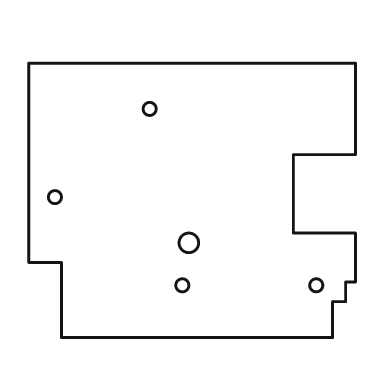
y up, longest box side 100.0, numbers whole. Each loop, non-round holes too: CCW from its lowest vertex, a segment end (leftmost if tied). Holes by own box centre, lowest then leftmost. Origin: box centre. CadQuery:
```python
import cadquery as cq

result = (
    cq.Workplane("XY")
    .moveTo(-40.0, -42.0)
    .lineTo(43.0, -42.0)
    .lineTo(43.0, -31.0)
    .lineTo(47.0, -31.0)
    .lineTo(47.0, -25.0)
    .lineTo(50.0, -25.0)
    .lineTo(50.0, -10.0)
    .lineTo(31.0, -10.0)
    .lineTo(31.0, 14.0)
    .lineTo(50.0, 14.0)
    .lineTo(50.0, 42.0)
    .lineTo(-50.0, 42.0)
    .lineTo(-50.0, -19.0)
    .lineTo(-40.0, -19.0)
    .close()
    .moveTo(-3.0, -26.0)
    .circle(2.0)
    .moveTo(38.0, -26.0)
    .circle(2.0)
    .moveTo(-1.0, -13.0)
    .circle(3.0)
    .moveTo(-42.0, 1.0)
    .circle(2.0)
    .moveTo(-13.0, 28.0)
    .circle(2.0)
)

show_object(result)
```